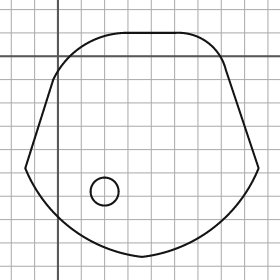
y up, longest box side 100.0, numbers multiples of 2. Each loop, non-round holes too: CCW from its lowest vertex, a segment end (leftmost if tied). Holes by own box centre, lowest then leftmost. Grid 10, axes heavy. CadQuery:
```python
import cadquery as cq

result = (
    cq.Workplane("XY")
    .moveTo(36.0, -86.0)
    .threePointArc((66.0, -74.0), (86.0, -48.0))
    .lineTo(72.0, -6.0)
    .threePointArc((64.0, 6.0), (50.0, 10.0))
    .lineTo(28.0, 10.0)
    .threePointArc((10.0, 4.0), (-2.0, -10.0))
    .lineTo(-14.0, -48.0)
    .threePointArc((6.0, -74.0), (36.0, -86.0))
    .close()
    .moveTo(20.0, -58.0)
    .circle(6.0)
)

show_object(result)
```